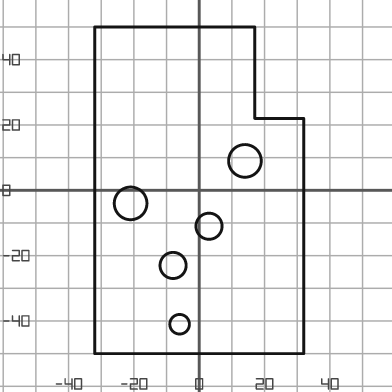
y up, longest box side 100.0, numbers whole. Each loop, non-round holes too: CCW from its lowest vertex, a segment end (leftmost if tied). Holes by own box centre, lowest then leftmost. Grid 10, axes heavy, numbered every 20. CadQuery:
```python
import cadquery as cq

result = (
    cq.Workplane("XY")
    .moveTo(-32.0, -50.0)
    .lineTo(32.0, -50.0)
    .lineTo(32.0, 22.0)
    .lineTo(17.0, 22.0)
    .lineTo(17.0, 50.0)
    .lineTo(-32.0, 50.0)
    .close()
    .moveTo(-6.0, -41.0)
    .circle(3.0)
    .moveTo(-8.0, -23.0)
    .circle(4.0)
    .moveTo(3.0, -11.0)
    .circle(4.0)
    .moveTo(-21.0, -4.0)
    .circle(5.0)
    .moveTo(14.0, 9.0)
    .circle(5.0)
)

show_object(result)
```